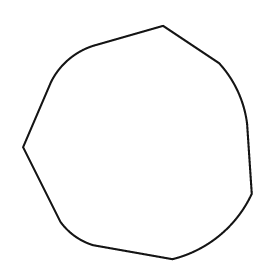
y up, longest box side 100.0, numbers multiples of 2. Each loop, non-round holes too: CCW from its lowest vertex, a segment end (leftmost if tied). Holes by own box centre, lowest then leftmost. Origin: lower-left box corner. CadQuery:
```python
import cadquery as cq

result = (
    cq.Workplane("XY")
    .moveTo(64.0, 0.0)
    .threePointArc((84.0, 10.0), (98.0, 28.0))
    .lineTo(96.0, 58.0)
    .threePointArc((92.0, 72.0), (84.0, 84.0))
    .lineTo(60.0, 100.0)
    .lineTo(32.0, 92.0)
    .threePointArc((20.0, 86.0), (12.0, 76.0))
    .lineTo(0.0, 48.0)
    .lineTo(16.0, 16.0)
    .threePointArc((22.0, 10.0), (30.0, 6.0))
    .close()
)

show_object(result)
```